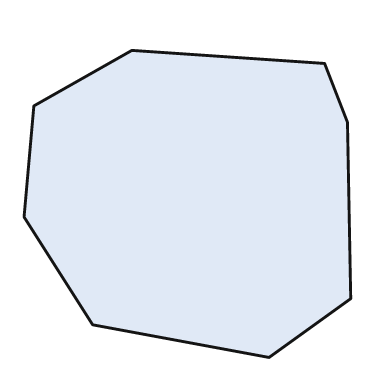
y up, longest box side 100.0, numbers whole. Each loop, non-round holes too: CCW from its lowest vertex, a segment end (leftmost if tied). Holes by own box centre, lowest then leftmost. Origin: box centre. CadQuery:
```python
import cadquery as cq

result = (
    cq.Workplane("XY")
    .moveTo(25.0, -47.0)
    .lineTo(50.0, -29.0)
    .lineTo(49.0, 25.0)
    .lineTo(42.0, 43.0)
    .lineTo(-17.0, 47.0)
    .lineTo(-47.0, 30.0)
    .lineTo(-50.0, -4.0)
    .lineTo(-29.0, -37.0)
    .close()
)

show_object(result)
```